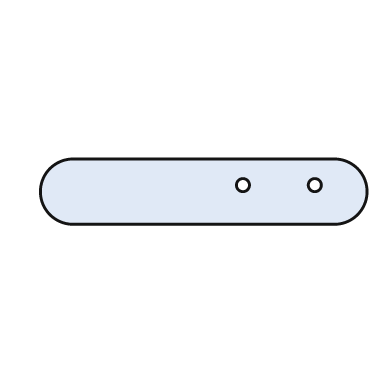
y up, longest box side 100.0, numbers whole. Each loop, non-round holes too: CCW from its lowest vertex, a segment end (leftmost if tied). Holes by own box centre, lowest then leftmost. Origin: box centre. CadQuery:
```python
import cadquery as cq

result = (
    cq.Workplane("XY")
    .moveTo(-40.0, -10.0)
    .lineTo(40.0, -10.0)
    .threePointArc((50.0, 0.0), (40.0, 10.0))
    .lineTo(-40.0, 10.0)
    .threePointArc((-50.0, 0.0), (-40.0, -10.0))
    .close()
    .moveTo(12.0, 2.0)
    .circle(2.0)
    .moveTo(34.0, 2.0)
    .circle(2.0)
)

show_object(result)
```